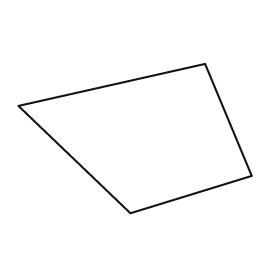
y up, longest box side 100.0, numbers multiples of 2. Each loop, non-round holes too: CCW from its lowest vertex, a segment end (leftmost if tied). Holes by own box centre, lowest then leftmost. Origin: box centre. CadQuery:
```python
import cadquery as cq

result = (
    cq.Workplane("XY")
    .moveTo(-2.0, -32.0)
    .lineTo(50.0, -16.0)
    .lineTo(30.0, 32.0)
    .lineTo(-50.0, 14.0)
    .close()
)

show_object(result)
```